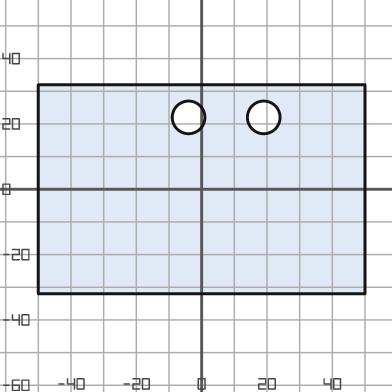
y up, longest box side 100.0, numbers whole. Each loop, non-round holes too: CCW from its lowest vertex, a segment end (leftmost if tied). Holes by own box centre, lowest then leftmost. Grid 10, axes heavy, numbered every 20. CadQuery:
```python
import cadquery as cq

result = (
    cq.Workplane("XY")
    .moveTo(-50.0, -32.0)
    .lineTo(50.0, -32.0)
    .lineTo(50.0, 32.0)
    .lineTo(-50.0, 32.0)
    .close()
    .moveTo(-4.0, 22.0)
    .circle(5.0)
    .moveTo(19.0, 22.0)
    .circle(5.0)
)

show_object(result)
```